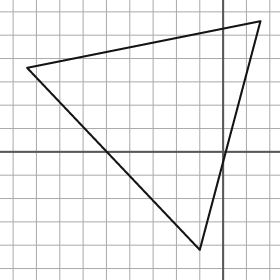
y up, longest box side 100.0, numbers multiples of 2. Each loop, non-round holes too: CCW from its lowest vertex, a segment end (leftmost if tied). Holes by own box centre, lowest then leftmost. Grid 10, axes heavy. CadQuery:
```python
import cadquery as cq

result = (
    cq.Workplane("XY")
    .moveTo(-10.0, -42.0)
    .lineTo(16.0, 56.0)
    .lineTo(-84.0, 36.0)
    .close()
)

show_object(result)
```